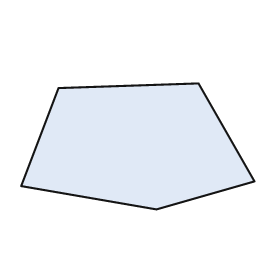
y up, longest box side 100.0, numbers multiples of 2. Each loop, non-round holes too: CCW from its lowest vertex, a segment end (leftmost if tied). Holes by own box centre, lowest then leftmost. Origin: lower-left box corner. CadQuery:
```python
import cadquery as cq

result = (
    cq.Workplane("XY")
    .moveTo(58.0, 0.0)
    .lineTo(100.0, 12.0)
    .lineTo(76.0, 54.0)
    .lineTo(16.0, 52.0)
    .lineTo(0.0, 10.0)
    .close()
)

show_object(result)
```